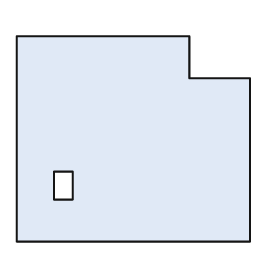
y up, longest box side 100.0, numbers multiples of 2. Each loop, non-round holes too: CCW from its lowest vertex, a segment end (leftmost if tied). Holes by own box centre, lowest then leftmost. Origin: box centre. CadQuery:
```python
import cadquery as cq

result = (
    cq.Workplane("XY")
    .moveTo(-50.0, -44.0)
    .lineTo(50.0, -44.0)
    .lineTo(50.0, 26.0)
    .lineTo(24.0, 26.0)
    .lineTo(24.0, 44.0)
    .lineTo(-50.0, 44.0)
    .close()
    .moveTo(-34.0, -26.0)
    .lineTo(-26.0, -26.0)
    .lineTo(-26.0, -14.0)
    .lineTo(-34.0, -14.0)
    .close()
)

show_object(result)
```